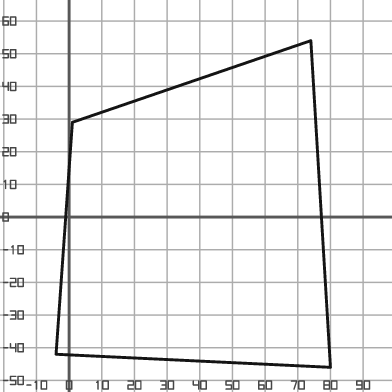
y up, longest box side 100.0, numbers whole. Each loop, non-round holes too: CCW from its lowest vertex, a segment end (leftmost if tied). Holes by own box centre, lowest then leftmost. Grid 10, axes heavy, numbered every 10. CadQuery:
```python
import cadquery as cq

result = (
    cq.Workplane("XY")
    .moveTo(80.0, -46.0)
    .lineTo(74.0, 54.0)
    .lineTo(1.0, 29.0)
    .lineTo(-4.0, -42.0)
    .close()
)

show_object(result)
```